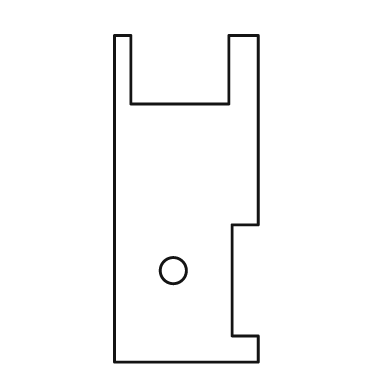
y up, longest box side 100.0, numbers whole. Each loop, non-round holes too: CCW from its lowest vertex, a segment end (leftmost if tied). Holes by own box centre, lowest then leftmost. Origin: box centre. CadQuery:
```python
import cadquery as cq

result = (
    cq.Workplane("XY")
    .moveTo(-22.0, -50.0)
    .lineTo(22.0, -50.0)
    .lineTo(22.0, -42.0)
    .lineTo(14.0, -42.0)
    .lineTo(14.0, -8.0)
    .lineTo(22.0, -8.0)
    .lineTo(22.0, 50.0)
    .lineTo(13.0, 50.0)
    .lineTo(13.0, 29.0)
    .lineTo(-17.0, 29.0)
    .lineTo(-17.0, 50.0)
    .lineTo(-22.0, 50.0)
    .close()
    .moveTo(-4.0, -22.0)
    .circle(4.0)
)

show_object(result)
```